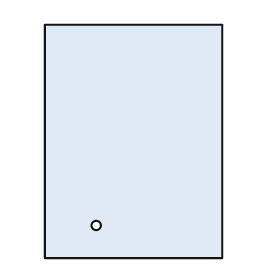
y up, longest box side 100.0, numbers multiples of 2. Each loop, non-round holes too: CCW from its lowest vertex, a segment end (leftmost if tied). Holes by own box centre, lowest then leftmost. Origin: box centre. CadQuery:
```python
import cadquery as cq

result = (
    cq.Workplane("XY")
    .moveTo(-38.0, -50.0)
    .lineTo(38.0, -50.0)
    .lineTo(38.0, 50.0)
    .lineTo(-38.0, 50.0)
    .close()
    .moveTo(-16.0, -36.0)
    .circle(2.0)
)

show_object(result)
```